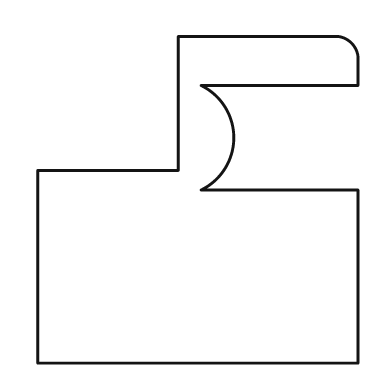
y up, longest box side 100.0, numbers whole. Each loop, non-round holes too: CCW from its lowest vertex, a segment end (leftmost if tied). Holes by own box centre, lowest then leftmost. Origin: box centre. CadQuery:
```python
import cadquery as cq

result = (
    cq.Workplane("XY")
    .moveTo(-49.0, -50.0)
    .lineTo(49.0, -50.0)
    .lineTo(49.0, 3.0)
    .lineTo(1.0, 3.0)
    .threePointArc((11.0, 19.0), (1.0, 35.0))
    .lineTo(49.0, 35.0)
    .lineTo(49.0, 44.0)
    .threePointArc((47.0, 48.0), (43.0, 50.0))
    .lineTo(-6.0, 50.0)
    .lineTo(-6.0, 9.0)
    .lineTo(-49.0, 9.0)
    .close()
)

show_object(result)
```